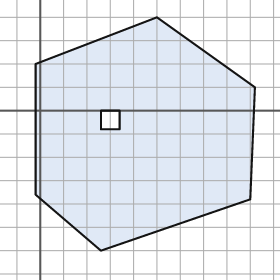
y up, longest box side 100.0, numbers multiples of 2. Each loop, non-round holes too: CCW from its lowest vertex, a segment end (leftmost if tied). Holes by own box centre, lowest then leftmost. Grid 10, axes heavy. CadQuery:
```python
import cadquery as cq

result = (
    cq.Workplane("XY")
    .moveTo(26.0, -60.0)
    .lineTo(90.0, -38.0)
    .lineTo(92.0, 10.0)
    .lineTo(50.0, 40.0)
    .lineTo(-2.0, 20.0)
    .lineTo(-2.0, -36.0)
    .close()
    .moveTo(26.0, -8.0)
    .lineTo(34.0, -8.0)
    .lineTo(34.0, 0.0)
    .lineTo(26.0, 0.0)
    .close()
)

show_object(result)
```